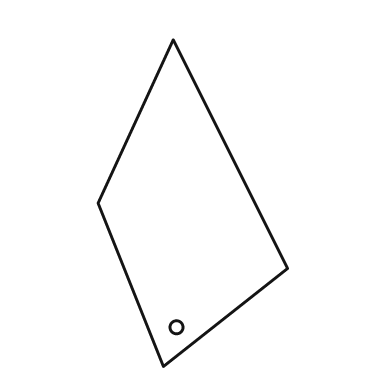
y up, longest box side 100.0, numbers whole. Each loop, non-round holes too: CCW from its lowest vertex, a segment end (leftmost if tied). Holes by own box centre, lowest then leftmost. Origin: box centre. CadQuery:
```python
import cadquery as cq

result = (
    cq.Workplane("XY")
    .moveTo(-9.0, -50.0)
    .lineTo(29.0, -20.0)
    .lineTo(-6.0, 50.0)
    .lineTo(-29.0, 0.0)
    .close()
    .moveTo(-5.0, -38.0)
    .circle(2.0)
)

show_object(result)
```